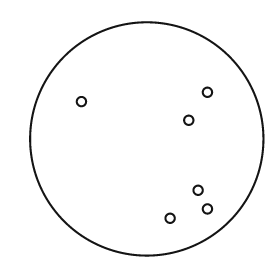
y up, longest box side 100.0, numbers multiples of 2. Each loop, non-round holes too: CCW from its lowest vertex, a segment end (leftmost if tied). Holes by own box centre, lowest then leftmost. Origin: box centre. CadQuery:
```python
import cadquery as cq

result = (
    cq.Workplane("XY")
    .moveTo(0.0, 0.0)
    .circle(50.0)
    .moveTo(10.0, -34.0)
    .circle(2.0)
    .moveTo(26.0, -30.0)
    .circle(2.0)
    .moveTo(22.0, -22.0)
    .circle(2.0)
    .moveTo(18.0, 8.0)
    .circle(2.0)
    .moveTo(-28.0, 16.0)
    .circle(2.0)
    .moveTo(26.0, 20.0)
    .circle(2.0)
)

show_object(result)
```